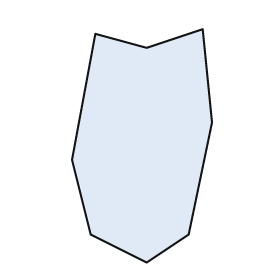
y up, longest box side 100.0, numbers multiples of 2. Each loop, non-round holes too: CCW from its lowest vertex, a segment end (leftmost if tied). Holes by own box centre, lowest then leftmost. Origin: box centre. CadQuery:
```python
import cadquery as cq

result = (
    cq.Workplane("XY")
    .moveTo(2.0, -50.0)
    .lineTo(20.0, -38.0)
    .lineTo(30.0, 10.0)
    .lineTo(26.0, 50.0)
    .lineTo(2.0, 42.0)
    .lineTo(-20.0, 48.0)
    .lineTo(-30.0, -6.0)
    .lineTo(-22.0, -38.0)
    .close()
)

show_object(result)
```